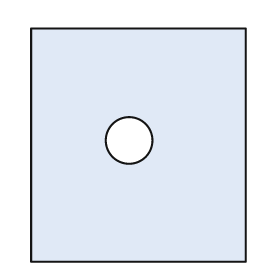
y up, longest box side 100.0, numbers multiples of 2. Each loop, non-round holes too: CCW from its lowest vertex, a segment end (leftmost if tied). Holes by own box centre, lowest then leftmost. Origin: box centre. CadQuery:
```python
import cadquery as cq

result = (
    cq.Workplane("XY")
    .moveTo(-46.0, -50.0)
    .lineTo(46.0, -50.0)
    .lineTo(46.0, 50.0)
    .lineTo(-46.0, 50.0)
    .close()
    .moveTo(-4.0, 2.0)
    .circle(10.0)
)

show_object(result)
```